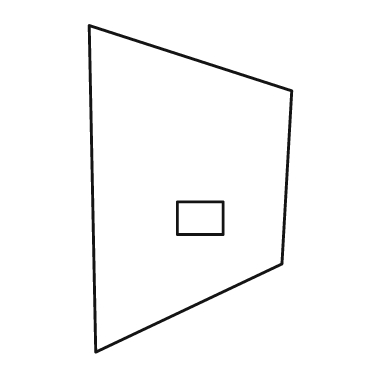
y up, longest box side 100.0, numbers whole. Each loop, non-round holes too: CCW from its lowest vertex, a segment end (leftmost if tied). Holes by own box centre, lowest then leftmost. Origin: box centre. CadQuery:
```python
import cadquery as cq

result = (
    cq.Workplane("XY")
    .moveTo(-29.0, -50.0)
    .lineTo(28.0, -23.0)
    .lineTo(31.0, 30.0)
    .lineTo(-31.0, 50.0)
    .close()
    .moveTo(-4.0, -14.0)
    .lineTo(10.0, -14.0)
    .lineTo(10.0, -4.0)
    .lineTo(-4.0, -4.0)
    .close()
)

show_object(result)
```